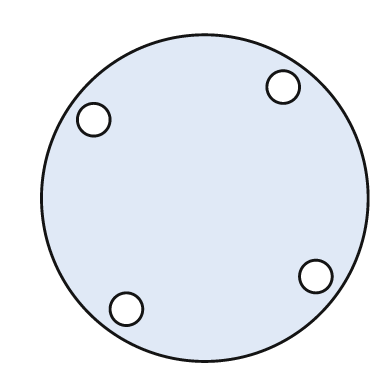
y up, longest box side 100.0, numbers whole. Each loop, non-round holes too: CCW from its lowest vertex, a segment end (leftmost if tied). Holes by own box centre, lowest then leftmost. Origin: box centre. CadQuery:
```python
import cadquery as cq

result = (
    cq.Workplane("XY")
    .moveTo(0.0, 0.0)
    .circle(50.0)
    .moveTo(-24.0, -34.0)
    .circle(5.0)
    .moveTo(34.0, -24.0)
    .circle(5.0)
    .moveTo(-34.0, 24.0)
    .circle(5.0)
    .moveTo(24.0, 34.0)
    .circle(5.0)
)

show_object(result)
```